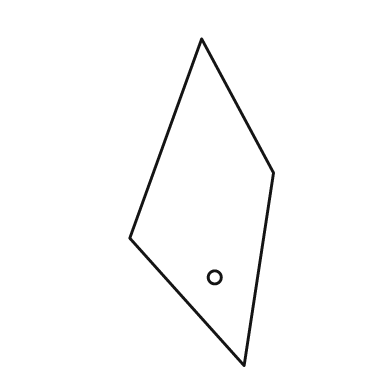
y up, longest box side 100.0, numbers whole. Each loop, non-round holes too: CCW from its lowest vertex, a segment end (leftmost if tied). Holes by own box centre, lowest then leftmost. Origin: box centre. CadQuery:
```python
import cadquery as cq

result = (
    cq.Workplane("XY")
    .moveTo(13.0, -50.0)
    .lineTo(22.0, 9.0)
    .lineTo(0.0, 50.0)
    .lineTo(-22.0, -11.0)
    .close()
    .moveTo(4.0, -23.0)
    .circle(2.0)
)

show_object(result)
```